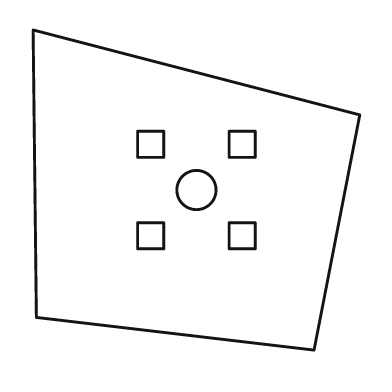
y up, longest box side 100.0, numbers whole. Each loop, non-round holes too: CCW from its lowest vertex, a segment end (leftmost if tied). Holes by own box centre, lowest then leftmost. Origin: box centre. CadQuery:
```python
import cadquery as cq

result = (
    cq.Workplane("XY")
    .moveTo(36.0, -49.0)
    .lineTo(50.0, 23.0)
    .lineTo(-50.0, 49.0)
    .lineTo(-49.0, -39.0)
    .close()
    .moveTo(-18.0, -18.0)
    .lineTo(-10.0, -18.0)
    .lineTo(-10.0, -10.0)
    .lineTo(-18.0, -10.0)
    .close()
    .moveTo(10.0, -18.0)
    .lineTo(18.0, -18.0)
    .lineTo(18.0, -10.0)
    .lineTo(10.0, -10.0)
    .close()
    .moveTo(0.0, 0.0)
    .circle(6.0)
    .moveTo(-18.0, 10.0)
    .lineTo(-10.0, 10.0)
    .lineTo(-10.0, 18.0)
    .lineTo(-18.0, 18.0)
    .close()
    .moveTo(10.0, 10.0)
    .lineTo(18.0, 10.0)
    .lineTo(18.0, 18.0)
    .lineTo(10.0, 18.0)
    .close()
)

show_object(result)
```